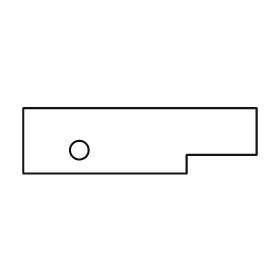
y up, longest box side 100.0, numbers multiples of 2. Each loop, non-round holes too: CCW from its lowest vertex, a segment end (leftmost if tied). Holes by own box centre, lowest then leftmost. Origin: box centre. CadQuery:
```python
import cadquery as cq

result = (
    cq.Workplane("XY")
    .moveTo(-50.0, -14.0)
    .lineTo(20.0, -14.0)
    .lineTo(20.0, -6.0)
    .lineTo(50.0, -6.0)
    .lineTo(50.0, 14.0)
    .lineTo(-50.0, 14.0)
    .close()
    .moveTo(-26.0, -4.0)
    .circle(4.0)
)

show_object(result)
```